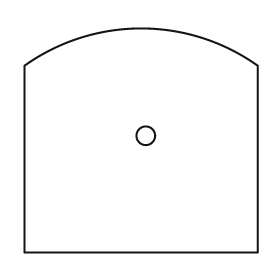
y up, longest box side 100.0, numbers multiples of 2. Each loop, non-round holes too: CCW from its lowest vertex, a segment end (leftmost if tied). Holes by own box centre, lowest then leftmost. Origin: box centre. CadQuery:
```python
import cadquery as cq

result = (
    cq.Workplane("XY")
    .moveTo(-50.0, -48.0)
    .lineTo(50.0, -48.0)
    .lineTo(50.0, 32.0)
    .threePointArc((0.0, 48.0), (-50.0, 32.0))
    .close()
    .moveTo(2.0, 2.0)
    .circle(4.0)
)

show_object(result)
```